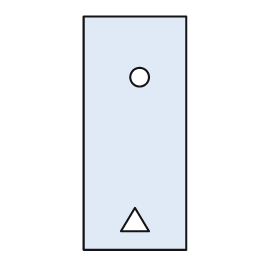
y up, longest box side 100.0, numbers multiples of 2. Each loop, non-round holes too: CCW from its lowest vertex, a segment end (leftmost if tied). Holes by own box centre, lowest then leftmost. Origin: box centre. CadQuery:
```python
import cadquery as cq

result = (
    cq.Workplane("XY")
    .moveTo(-22.0, -50.0)
    .lineTo(22.0, -50.0)
    .lineTo(22.0, 50.0)
    .lineTo(-22.0, 50.0)
    .close()
    .moveTo(-6.0, -42.0)
    .lineTo(6.0, -42.0)
    .lineTo(0.0, -32.0)
    .close()
    .moveTo(2.0, 24.0)
    .circle(4.0)
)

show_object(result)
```